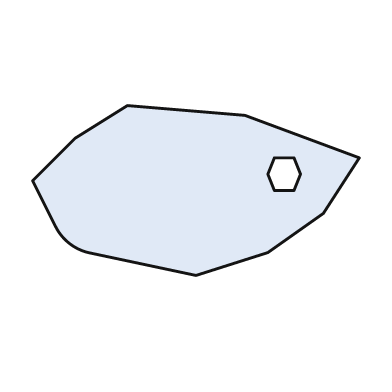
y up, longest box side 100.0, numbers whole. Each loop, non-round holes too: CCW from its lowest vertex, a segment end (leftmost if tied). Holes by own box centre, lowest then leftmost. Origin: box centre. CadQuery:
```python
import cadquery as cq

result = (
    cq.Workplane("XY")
    .moveTo(0.0, -26.0)
    .lineTo(22.0, -19.0)
    .lineTo(39.0, -7.0)
    .lineTo(50.0, 10.0)
    .lineTo(15.0, 23.0)
    .lineTo(-21.0, 26.0)
    .lineTo(-37.0, 16.0)
    .lineTo(-50.0, 3.0)
    .lineTo(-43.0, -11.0)
    .threePointArc((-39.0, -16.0), (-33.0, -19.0))
    .close()
    .moveTo(24.0, 0.0)
    .lineTo(30.0, 0.0)
    .lineTo(32.0, 5.0)
    .lineTo(30.0, 10.0)
    .lineTo(24.0, 10.0)
    .lineTo(22.0, 5.0)
    .close()
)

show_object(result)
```